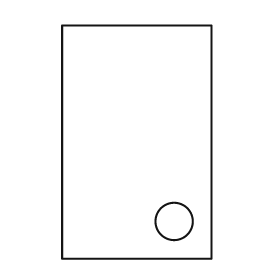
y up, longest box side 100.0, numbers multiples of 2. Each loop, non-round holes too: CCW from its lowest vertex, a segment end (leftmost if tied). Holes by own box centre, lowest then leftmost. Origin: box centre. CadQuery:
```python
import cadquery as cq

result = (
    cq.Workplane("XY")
    .moveTo(-32.0, -50.0)
    .lineTo(32.0, -50.0)
    .lineTo(32.0, 50.0)
    .lineTo(-32.0, 50.0)
    .close()
    .moveTo(16.0, -34.0)
    .circle(8.0)
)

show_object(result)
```